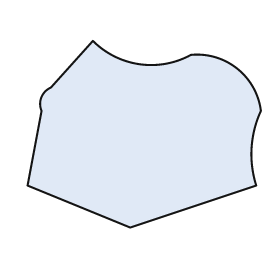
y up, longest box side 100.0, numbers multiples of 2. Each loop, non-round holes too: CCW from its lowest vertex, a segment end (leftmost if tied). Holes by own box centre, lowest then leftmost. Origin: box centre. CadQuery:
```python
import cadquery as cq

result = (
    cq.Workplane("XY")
    .moveTo(-6.0, -40.0)
    .lineTo(48.0, -22.0)
    .threePointArc((46.0, -6.0), (50.0, 10.0))
    .threePointArc((40.0, 28.0), (20.0, 34.0))
    .threePointArc((-2.0, 30.0), (-22.0, 40.0))
    .lineTo(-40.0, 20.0)
    .threePointArc((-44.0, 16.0), (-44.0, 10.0))
    .lineTo(-50.0, -22.0)
    .close()
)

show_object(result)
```